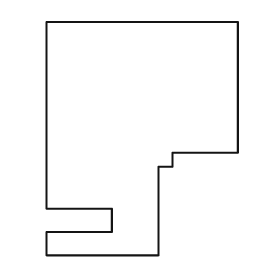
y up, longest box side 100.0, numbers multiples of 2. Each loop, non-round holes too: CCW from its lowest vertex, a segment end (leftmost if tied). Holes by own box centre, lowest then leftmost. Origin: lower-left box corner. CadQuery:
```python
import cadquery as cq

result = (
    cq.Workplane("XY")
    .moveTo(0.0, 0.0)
    .lineTo(48.0, 0.0)
    .lineTo(48.0, 38.0)
    .lineTo(54.0, 38.0)
    .lineTo(54.0, 44.0)
    .lineTo(82.0, 44.0)
    .lineTo(82.0, 100.0)
    .lineTo(0.0, 100.0)
    .lineTo(0.0, 20.0)
    .lineTo(28.0, 20.0)
    .lineTo(28.0, 10.0)
    .lineTo(0.0, 10.0)
    .close()
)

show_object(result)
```